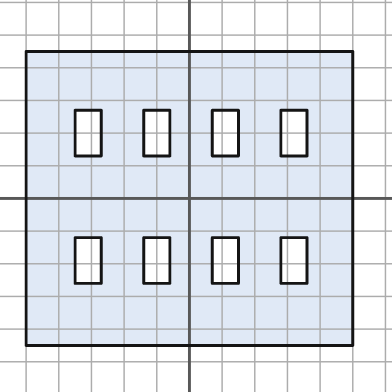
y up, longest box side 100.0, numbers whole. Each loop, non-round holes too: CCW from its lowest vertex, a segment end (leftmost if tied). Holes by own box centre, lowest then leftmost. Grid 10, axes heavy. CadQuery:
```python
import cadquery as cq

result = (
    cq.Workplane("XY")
    .moveTo(-50.0, -45.0)
    .lineTo(50.0, -45.0)
    .lineTo(50.0, 45.0)
    .lineTo(-50.0, 45.0)
    .close()
    .moveTo(-35.0, -26.0)
    .lineTo(-27.0, -26.0)
    .lineTo(-27.0, -12.0)
    .lineTo(-35.0, -12.0)
    .close()
    .moveTo(-14.0, -26.0)
    .lineTo(-6.0, -26.0)
    .lineTo(-6.0, -12.0)
    .lineTo(-14.0, -12.0)
    .close()
    .moveTo(7.0, -26.0)
    .lineTo(15.0, -26.0)
    .lineTo(15.0, -12.0)
    .lineTo(7.0, -12.0)
    .close()
    .moveTo(28.0, -26.0)
    .lineTo(36.0, -26.0)
    .lineTo(36.0, -12.0)
    .lineTo(28.0, -12.0)
    .close()
    .moveTo(-35.0, 13.0)
    .lineTo(-27.0, 13.0)
    .lineTo(-27.0, 27.0)
    .lineTo(-35.0, 27.0)
    .close()
    .moveTo(-14.0, 13.0)
    .lineTo(-6.0, 13.0)
    .lineTo(-6.0, 27.0)
    .lineTo(-14.0, 27.0)
    .close()
    .moveTo(7.0, 13.0)
    .lineTo(15.0, 13.0)
    .lineTo(15.0, 27.0)
    .lineTo(7.0, 27.0)
    .close()
    .moveTo(28.0, 13.0)
    .lineTo(36.0, 13.0)
    .lineTo(36.0, 27.0)
    .lineTo(28.0, 27.0)
    .close()
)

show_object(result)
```